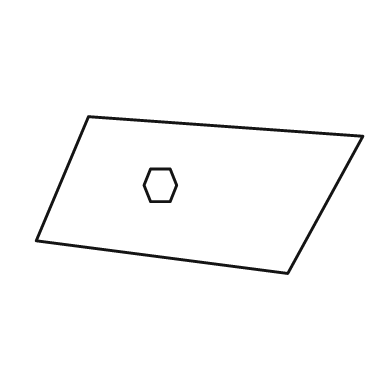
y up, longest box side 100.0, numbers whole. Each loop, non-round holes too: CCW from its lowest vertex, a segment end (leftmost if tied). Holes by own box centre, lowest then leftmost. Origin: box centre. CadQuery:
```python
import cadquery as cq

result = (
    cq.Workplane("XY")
    .moveTo(27.0, -24.0)
    .lineTo(50.0, 18.0)
    .lineTo(-34.0, 24.0)
    .lineTo(-50.0, -14.0)
    .close()
    .moveTo(-15.0, -2.0)
    .lineTo(-9.0, -2.0)
    .lineTo(-7.0, 3.0)
    .lineTo(-9.0, 8.0)
    .lineTo(-15.0, 8.0)
    .lineTo(-17.0, 3.0)
    .close()
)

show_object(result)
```